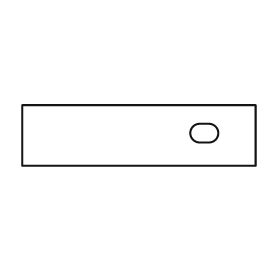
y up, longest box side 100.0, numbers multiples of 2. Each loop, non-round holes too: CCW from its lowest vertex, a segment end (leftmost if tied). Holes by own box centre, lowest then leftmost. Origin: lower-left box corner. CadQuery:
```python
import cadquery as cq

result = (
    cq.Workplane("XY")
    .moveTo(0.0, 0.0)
    .lineTo(100.0, 0.0)
    .lineTo(100.0, 26.0)
    .lineTo(0.0, 26.0)
    .close()
    .moveTo(76.0, 10.0)
    .lineTo(80.0, 10.0)
    .threePointArc((84.0, 14.0), (80.0, 18.0))
    .lineTo(76.0, 18.0)
    .threePointArc((72.0, 14.0), (76.0, 10.0))
    .close()
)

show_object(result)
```